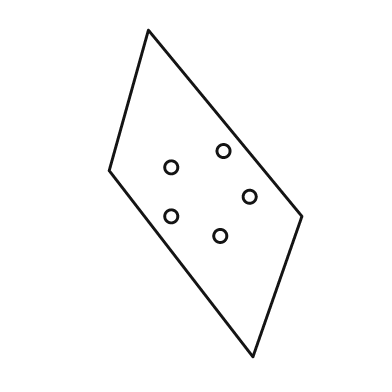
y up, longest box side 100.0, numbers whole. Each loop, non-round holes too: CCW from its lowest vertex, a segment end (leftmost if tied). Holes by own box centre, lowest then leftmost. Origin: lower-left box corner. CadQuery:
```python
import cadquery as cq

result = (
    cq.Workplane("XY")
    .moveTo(44.0, 0.0)
    .lineTo(59.0, 43.0)
    .lineTo(12.0, 100.0)
    .lineTo(0.0, 57.0)
    .close()
    .moveTo(34.0, 37.0)
    .circle(2.0)
    .moveTo(19.0, 43.0)
    .circle(2.0)
    .moveTo(43.0, 49.0)
    .circle(2.0)
    .moveTo(19.0, 58.0)
    .circle(2.0)
    .moveTo(35.0, 63.0)
    .circle(2.0)
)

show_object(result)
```